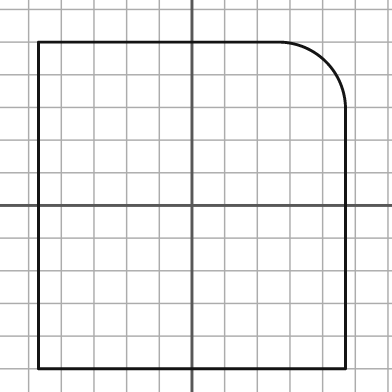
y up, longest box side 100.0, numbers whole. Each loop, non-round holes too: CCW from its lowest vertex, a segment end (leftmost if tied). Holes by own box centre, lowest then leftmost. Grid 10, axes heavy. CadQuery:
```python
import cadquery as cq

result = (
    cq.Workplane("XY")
    .moveTo(-47.0, -50.0)
    .lineTo(47.0, -50.0)
    .lineTo(47.0, 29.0)
    .threePointArc((41.0, 44.0), (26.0, 50.0))
    .lineTo(-47.0, 50.0)
    .close()
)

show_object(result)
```